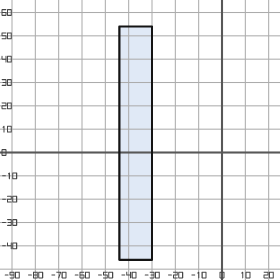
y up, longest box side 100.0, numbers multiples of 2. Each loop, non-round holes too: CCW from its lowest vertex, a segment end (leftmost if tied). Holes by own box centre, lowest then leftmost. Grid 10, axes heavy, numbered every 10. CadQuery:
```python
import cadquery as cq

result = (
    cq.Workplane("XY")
    .moveTo(-44.0, -46.0)
    .lineTo(-30.0, -46.0)
    .lineTo(-30.0, 54.0)
    .lineTo(-44.0, 54.0)
    .close()
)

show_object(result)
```